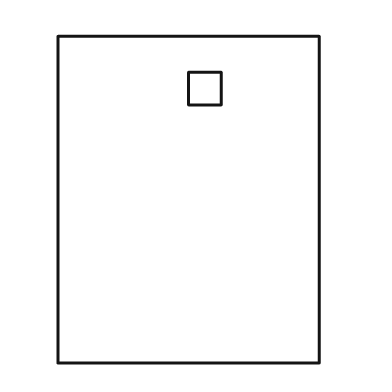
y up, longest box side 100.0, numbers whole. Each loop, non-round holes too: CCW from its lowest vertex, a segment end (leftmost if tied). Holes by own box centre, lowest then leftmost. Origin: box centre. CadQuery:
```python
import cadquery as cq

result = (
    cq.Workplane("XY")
    .moveTo(-40.0, -50.0)
    .lineTo(40.0, -50.0)
    .lineTo(40.0, 50.0)
    .lineTo(-40.0, 50.0)
    .close()
    .moveTo(0.0, 29.0)
    .lineTo(10.0, 29.0)
    .lineTo(10.0, 39.0)
    .lineTo(0.0, 39.0)
    .close()
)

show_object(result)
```